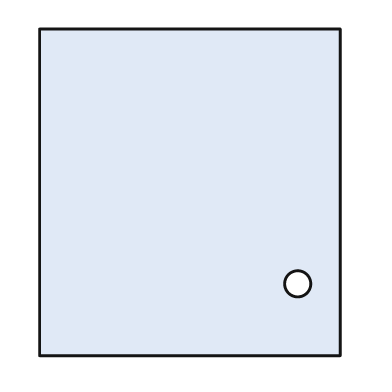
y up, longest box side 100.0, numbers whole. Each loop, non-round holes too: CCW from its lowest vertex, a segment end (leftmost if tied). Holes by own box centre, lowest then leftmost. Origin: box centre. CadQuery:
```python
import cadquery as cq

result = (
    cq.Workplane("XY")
    .moveTo(-46.0, -50.0)
    .lineTo(46.0, -50.0)
    .lineTo(46.0, 50.0)
    .lineTo(-46.0, 50.0)
    .close()
    .moveTo(33.0, -28.0)
    .circle(4.0)
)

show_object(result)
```